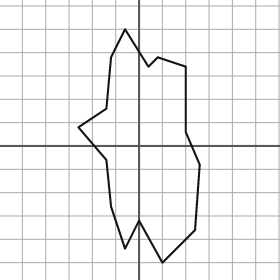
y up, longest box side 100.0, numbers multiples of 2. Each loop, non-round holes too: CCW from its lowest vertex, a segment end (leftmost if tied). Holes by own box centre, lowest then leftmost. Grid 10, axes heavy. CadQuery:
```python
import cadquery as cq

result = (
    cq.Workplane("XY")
    .moveTo(10.0, -50.0)
    .lineTo(24.0, -36.0)
    .lineTo(26.0, -8.0)
    .lineTo(20.0, 6.0)
    .lineTo(20.0, 34.0)
    .lineTo(8.0, 38.0)
    .lineTo(4.0, 34.0)
    .lineTo(-6.0, 50.0)
    .lineTo(-12.0, 38.0)
    .lineTo(-14.0, 16.0)
    .lineTo(-26.0, 8.0)
    .lineTo(-14.0, -6.0)
    .lineTo(-12.0, -26.0)
    .lineTo(-6.0, -44.0)
    .lineTo(0.0, -32.0)
    .close()
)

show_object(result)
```